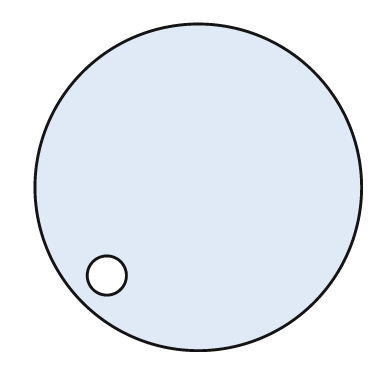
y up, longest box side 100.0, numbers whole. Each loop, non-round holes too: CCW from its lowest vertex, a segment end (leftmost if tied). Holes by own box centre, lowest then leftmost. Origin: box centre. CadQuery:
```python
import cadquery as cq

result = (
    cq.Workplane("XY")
    .moveTo(0.0, 0.0)
    .circle(50.0)
    .moveTo(-28.0, -27.0)
    .circle(6.0)
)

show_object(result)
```